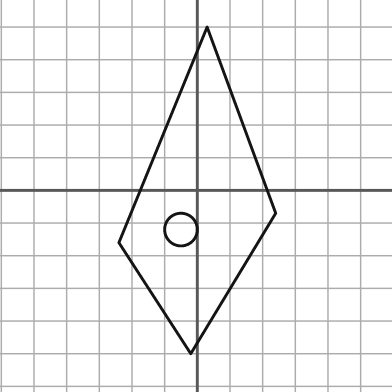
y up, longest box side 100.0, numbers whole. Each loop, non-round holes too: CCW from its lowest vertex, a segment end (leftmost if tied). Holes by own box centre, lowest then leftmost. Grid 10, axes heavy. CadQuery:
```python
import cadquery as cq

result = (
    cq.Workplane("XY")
    .moveTo(-2.0, -50.0)
    .lineTo(24.0, -7.0)
    .lineTo(3.0, 50.0)
    .lineTo(-24.0, -16.0)
    .close()
    .moveTo(-5.0, -12.0)
    .circle(5.0)
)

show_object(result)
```